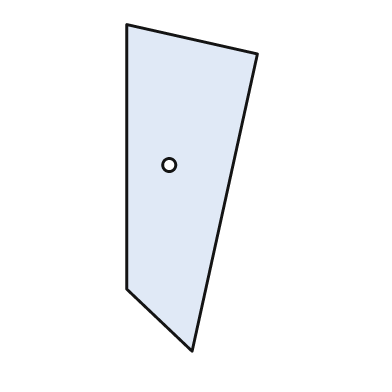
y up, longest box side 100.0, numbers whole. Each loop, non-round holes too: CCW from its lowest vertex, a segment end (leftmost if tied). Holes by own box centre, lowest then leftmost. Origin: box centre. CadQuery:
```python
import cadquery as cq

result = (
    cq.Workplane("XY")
    .moveTo(0.0, -50.0)
    .lineTo(20.0, 41.0)
    .lineTo(-20.0, 50.0)
    .lineTo(-20.0, -31.0)
    .close()
    .moveTo(-7.0, 7.0)
    .circle(2.0)
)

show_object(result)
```